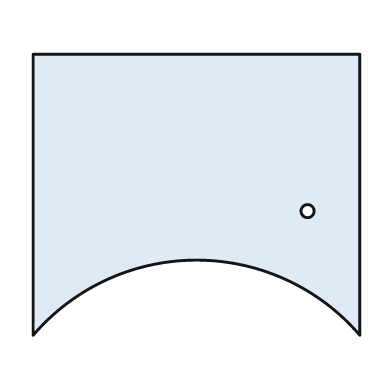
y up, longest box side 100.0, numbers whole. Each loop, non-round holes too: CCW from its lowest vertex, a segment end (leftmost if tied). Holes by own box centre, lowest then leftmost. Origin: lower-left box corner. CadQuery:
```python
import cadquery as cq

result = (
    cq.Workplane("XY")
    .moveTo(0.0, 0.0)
    .threePointArc((50.0, 23.0), (100.0, 0.0))
    .lineTo(100.0, 86.0)
    .lineTo(0.0, 86.0)
    .close()
    .moveTo(84.0, 38.0)
    .circle(2.0)
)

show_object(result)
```